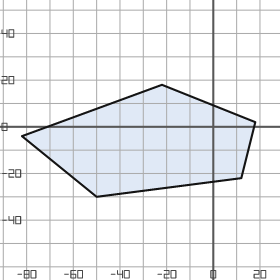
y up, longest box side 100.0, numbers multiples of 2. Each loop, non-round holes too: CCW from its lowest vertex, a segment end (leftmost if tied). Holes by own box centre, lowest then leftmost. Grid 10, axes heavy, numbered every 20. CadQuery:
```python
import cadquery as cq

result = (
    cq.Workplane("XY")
    .moveTo(-50.0, -30.0)
    .lineTo(12.0, -22.0)
    .lineTo(18.0, 2.0)
    .lineTo(-22.0, 18.0)
    .lineTo(-82.0, -4.0)
    .close()
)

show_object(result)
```